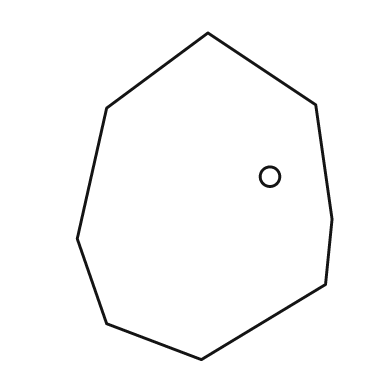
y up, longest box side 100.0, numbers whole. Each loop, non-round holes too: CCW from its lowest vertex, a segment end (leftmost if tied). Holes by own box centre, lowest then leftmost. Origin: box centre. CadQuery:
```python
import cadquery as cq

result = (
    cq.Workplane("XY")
    .moveTo(-1.0, -50.0)
    .lineTo(37.0, -27.0)
    .lineTo(39.0, -7.0)
    .lineTo(34.0, 28.0)
    .lineTo(1.0, 50.0)
    .lineTo(-30.0, 27.0)
    .lineTo(-39.0, -13.0)
    .lineTo(-30.0, -39.0)
    .close()
    .moveTo(20.0, 6.0)
    .circle(3.0)
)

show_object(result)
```